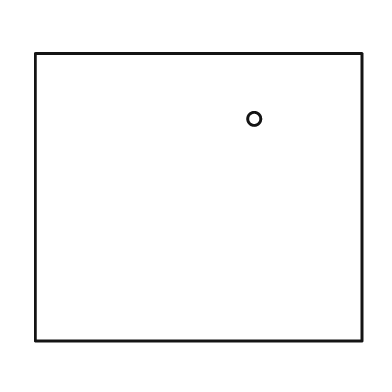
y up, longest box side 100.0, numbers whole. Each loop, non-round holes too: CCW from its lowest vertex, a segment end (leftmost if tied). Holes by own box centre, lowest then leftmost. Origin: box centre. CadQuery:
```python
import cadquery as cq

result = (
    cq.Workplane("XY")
    .moveTo(-50.0, -44.0)
    .lineTo(50.0, -44.0)
    .lineTo(50.0, 44.0)
    .lineTo(-50.0, 44.0)
    .close()
    .moveTo(17.0, 24.0)
    .circle(2.0)
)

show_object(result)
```